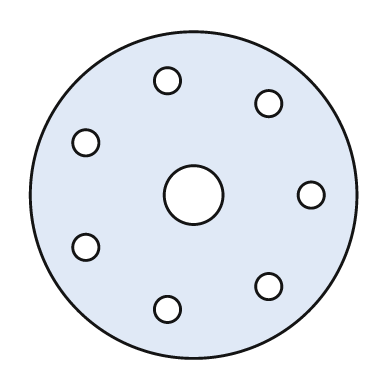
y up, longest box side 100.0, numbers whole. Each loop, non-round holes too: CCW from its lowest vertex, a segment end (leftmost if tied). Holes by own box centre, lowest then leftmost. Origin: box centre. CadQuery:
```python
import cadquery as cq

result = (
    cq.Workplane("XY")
    .moveTo(0.0, 0.0)
    .circle(50.0)
    .moveTo(-8.0, -35.0)
    .circle(4.0)
    .moveTo(23.0, -28.0)
    .circle(4.0)
    .moveTo(-33.0, -16.0)
    .circle(4.0)
    .moveTo(0.0, 0.0)
    .circle(9.0)
    .moveTo(36.0, 0.0)
    .circle(4.0)
    .moveTo(-33.0, 16.0)
    .circle(4.0)
    .moveTo(23.0, 28.0)
    .circle(4.0)
    .moveTo(-8.0, 35.0)
    .circle(4.0)
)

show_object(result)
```